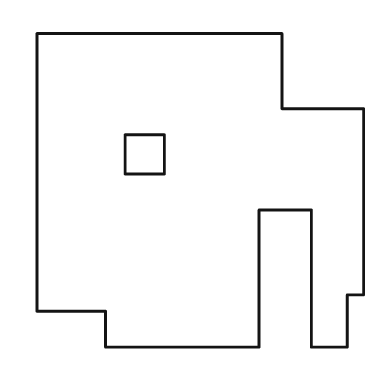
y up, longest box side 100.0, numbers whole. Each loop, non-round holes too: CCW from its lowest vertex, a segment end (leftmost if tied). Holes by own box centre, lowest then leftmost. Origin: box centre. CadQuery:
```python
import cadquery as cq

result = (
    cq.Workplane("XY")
    .moveTo(-29.0, -48.0)
    .lineTo(18.0, -48.0)
    .lineTo(18.0, -6.0)
    .lineTo(34.0, -6.0)
    .lineTo(34.0, -48.0)
    .lineTo(45.0, -48.0)
    .lineTo(45.0, -32.0)
    .lineTo(50.0, -32.0)
    .lineTo(50.0, 25.0)
    .lineTo(25.0, 25.0)
    .lineTo(25.0, 48.0)
    .lineTo(-50.0, 48.0)
    .lineTo(-50.0, -37.0)
    .lineTo(-29.0, -37.0)
    .close()
    .moveTo(-23.0, 5.0)
    .lineTo(-11.0, 5.0)
    .lineTo(-11.0, 17.0)
    .lineTo(-23.0, 17.0)
    .close()
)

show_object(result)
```